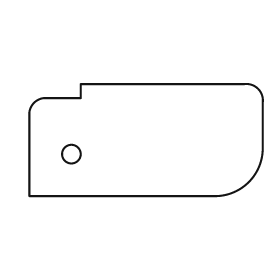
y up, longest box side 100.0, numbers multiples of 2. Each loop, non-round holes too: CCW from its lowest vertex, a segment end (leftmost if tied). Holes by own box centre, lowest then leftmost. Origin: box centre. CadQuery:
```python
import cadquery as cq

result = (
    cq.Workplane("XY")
    .moveTo(-50.0, -24.0)
    .lineTo(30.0, -24.0)
    .threePointArc((44.0, -18.0), (50.0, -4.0))
    .lineTo(50.0, 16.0)
    .threePointArc((48.0, 22.0), (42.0, 24.0))
    .lineTo(-28.0, 24.0)
    .lineTo(-28.0, 18.0)
    .lineTo(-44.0, 18.0)
    .threePointArc((-48.0, 16.0), (-50.0, 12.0))
    .close()
    .moveTo(-32.0, -6.0)
    .circle(4.0)
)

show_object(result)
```